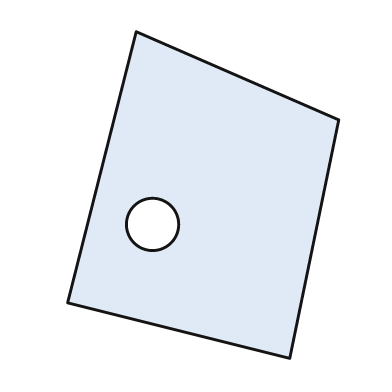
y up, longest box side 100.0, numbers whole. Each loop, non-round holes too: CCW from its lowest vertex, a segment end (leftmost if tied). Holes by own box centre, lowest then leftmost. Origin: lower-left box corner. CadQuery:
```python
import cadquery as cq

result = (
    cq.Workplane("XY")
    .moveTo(68.0, 0.0)
    .lineTo(83.0, 73.0)
    .lineTo(21.0, 100.0)
    .lineTo(0.0, 17.0)
    .close()
    .moveTo(26.0, 41.0)
    .circle(8.0)
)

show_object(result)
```